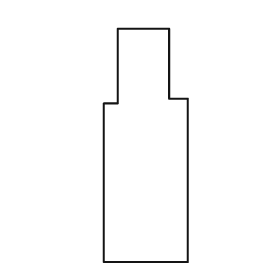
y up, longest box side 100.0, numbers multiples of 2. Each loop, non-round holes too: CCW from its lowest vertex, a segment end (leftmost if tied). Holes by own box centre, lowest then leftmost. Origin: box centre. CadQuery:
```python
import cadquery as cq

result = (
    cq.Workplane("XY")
    .moveTo(-18.0, -50.0)
    .lineTo(18.0, -50.0)
    .lineTo(18.0, 20.0)
    .lineTo(10.0, 20.0)
    .lineTo(10.0, 50.0)
    .lineTo(-12.0, 50.0)
    .lineTo(-12.0, 18.0)
    .lineTo(-18.0, 18.0)
    .close()
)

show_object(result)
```